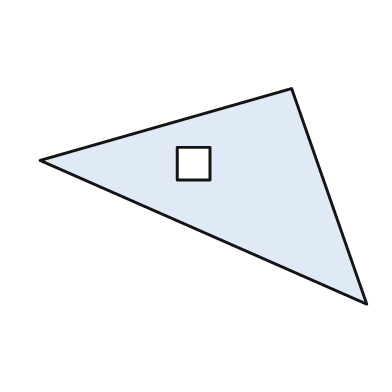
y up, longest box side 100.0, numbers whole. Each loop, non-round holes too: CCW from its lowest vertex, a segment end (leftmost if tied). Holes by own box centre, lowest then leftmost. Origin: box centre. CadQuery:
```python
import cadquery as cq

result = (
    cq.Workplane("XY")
    .moveTo(50.0, -33.0)
    .lineTo(27.0, 33.0)
    .lineTo(-50.0, 11.0)
    .close()
    .moveTo(-8.0, 5.0)
    .lineTo(2.0, 5.0)
    .lineTo(2.0, 15.0)
    .lineTo(-8.0, 15.0)
    .close()
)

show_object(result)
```